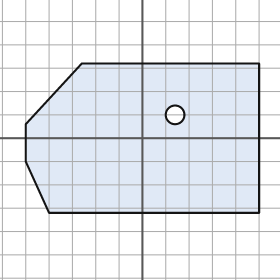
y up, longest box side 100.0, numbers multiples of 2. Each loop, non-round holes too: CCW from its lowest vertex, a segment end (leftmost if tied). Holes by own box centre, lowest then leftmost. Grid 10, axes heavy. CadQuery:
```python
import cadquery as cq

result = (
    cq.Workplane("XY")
    .moveTo(-40.0, -32.0)
    .lineTo(50.0, -32.0)
    .lineTo(50.0, 32.0)
    .lineTo(-26.0, 32.0)
    .lineTo(-50.0, 6.0)
    .lineTo(-50.0, -10.0)
    .close()
    .moveTo(14.0, 10.0)
    .circle(4.0)
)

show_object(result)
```